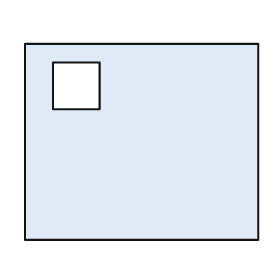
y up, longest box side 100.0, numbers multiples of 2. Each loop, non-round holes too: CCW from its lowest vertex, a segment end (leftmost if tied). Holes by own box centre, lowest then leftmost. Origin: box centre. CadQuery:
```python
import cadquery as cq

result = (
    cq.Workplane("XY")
    .moveTo(-50.0, -42.0)
    .lineTo(50.0, -42.0)
    .lineTo(50.0, 42.0)
    .lineTo(-50.0, 42.0)
    .close()
    .moveTo(-38.0, 14.0)
    .lineTo(-18.0, 14.0)
    .lineTo(-18.0, 34.0)
    .lineTo(-38.0, 34.0)
    .close()
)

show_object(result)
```